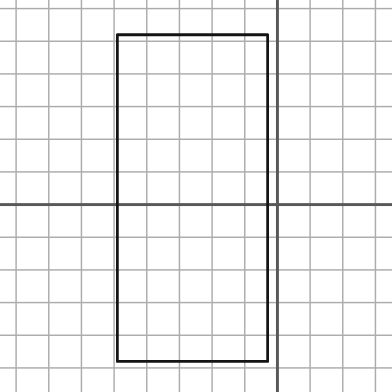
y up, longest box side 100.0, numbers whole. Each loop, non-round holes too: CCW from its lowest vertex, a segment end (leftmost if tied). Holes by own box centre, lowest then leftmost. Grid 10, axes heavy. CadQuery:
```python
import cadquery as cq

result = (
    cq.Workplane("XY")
    .moveTo(-49.0, -48.0)
    .lineTo(-3.0, -48.0)
    .lineTo(-3.0, 52.0)
    .lineTo(-49.0, 52.0)
    .close()
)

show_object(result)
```